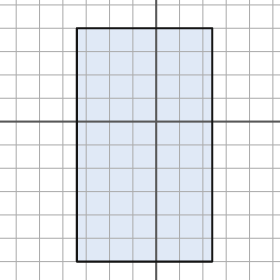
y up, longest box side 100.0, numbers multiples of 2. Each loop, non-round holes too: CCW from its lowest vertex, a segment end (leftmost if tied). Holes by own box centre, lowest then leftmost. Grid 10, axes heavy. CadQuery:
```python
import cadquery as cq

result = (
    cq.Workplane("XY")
    .moveTo(-34.0, -60.0)
    .lineTo(24.0, -60.0)
    .lineTo(24.0, 40.0)
    .lineTo(-34.0, 40.0)
    .close()
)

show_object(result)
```